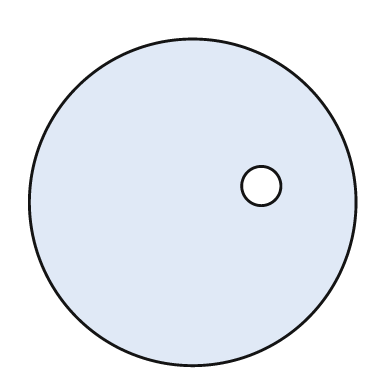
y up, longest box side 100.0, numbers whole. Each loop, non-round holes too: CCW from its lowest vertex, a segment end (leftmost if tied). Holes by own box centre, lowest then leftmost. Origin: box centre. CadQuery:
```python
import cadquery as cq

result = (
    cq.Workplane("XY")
    .moveTo(0.0, 0.0)
    .circle(50.0)
    .moveTo(21.0, 5.0)
    .circle(6.0)
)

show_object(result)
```